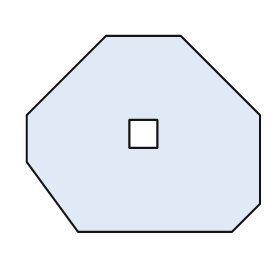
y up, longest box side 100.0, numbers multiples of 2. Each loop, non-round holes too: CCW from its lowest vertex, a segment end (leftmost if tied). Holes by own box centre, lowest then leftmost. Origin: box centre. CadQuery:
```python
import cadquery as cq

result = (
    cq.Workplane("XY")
    .moveTo(-28.0, -42.0)
    .lineTo(38.0, -42.0)
    .lineTo(50.0, -30.0)
    .lineTo(50.0, 8.0)
    .lineTo(16.0, 42.0)
    .lineTo(-16.0, 42.0)
    .lineTo(-50.0, 8.0)
    .lineTo(-50.0, -12.0)
    .close()
    .moveTo(-6.0, -6.0)
    .lineTo(6.0, -6.0)
    .lineTo(6.0, 6.0)
    .lineTo(-6.0, 6.0)
    .close()
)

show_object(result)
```